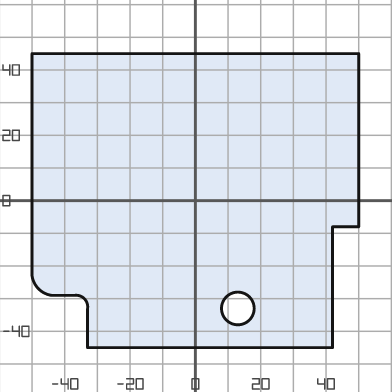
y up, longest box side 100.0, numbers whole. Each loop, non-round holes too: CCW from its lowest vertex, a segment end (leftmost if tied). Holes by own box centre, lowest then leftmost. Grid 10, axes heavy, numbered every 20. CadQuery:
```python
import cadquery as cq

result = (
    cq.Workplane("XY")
    .moveTo(-33.0, -45.0)
    .lineTo(42.0, -45.0)
    .lineTo(42.0, -8.0)
    .lineTo(50.0, -8.0)
    .lineTo(50.0, 45.0)
    .lineTo(-50.0, 45.0)
    .lineTo(-50.0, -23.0)
    .threePointArc((-48.0, -27.0), (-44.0, -29.0))
    .lineTo(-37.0, -29.0)
    .threePointArc((-34.0, -30.0), (-33.0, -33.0))
    .close()
    .moveTo(13.0, -33.0)
    .circle(5.0)
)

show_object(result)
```